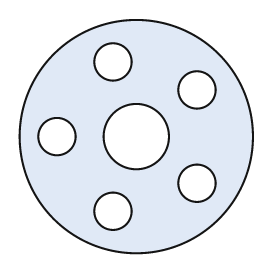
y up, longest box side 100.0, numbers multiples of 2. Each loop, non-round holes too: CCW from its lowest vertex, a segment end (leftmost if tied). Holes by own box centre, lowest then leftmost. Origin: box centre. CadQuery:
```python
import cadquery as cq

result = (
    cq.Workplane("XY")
    .moveTo(0.0, 0.0)
    .circle(50.0)
    .moveTo(-10.0, -32.0)
    .circle(8.0)
    .moveTo(26.0, -20.0)
    .circle(8.0)
    .moveTo(-34.0, 0.0)
    .circle(8.0)
    .moveTo(0.0, 0.0)
    .circle(14.0)
    .moveTo(26.0, 20.0)
    .circle(8.0)
    .moveTo(-10.0, 32.0)
    .circle(8.0)
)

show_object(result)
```